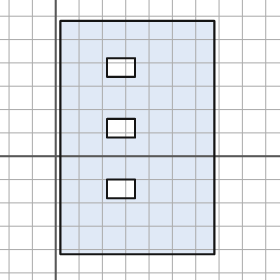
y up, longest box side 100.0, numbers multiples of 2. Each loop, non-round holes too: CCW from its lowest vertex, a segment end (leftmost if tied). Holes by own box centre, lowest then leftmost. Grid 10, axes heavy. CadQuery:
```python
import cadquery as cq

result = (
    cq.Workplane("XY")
    .moveTo(2.0, -42.0)
    .lineTo(68.0, -42.0)
    .lineTo(68.0, 58.0)
    .lineTo(2.0, 58.0)
    .close()
    .moveTo(22.0, -18.0)
    .lineTo(34.0, -18.0)
    .lineTo(34.0, -10.0)
    .lineTo(22.0, -10.0)
    .close()
    .moveTo(22.0, 8.0)
    .lineTo(34.0, 8.0)
    .lineTo(34.0, 16.0)
    .lineTo(22.0, 16.0)
    .close()
    .moveTo(22.0, 34.0)
    .lineTo(34.0, 34.0)
    .lineTo(34.0, 42.0)
    .lineTo(22.0, 42.0)
    .close()
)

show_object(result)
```